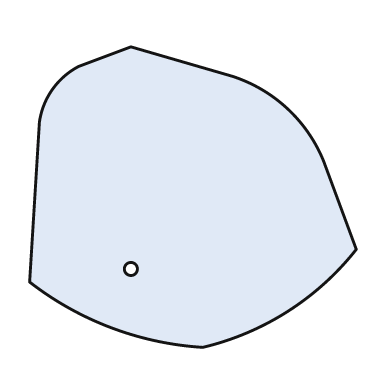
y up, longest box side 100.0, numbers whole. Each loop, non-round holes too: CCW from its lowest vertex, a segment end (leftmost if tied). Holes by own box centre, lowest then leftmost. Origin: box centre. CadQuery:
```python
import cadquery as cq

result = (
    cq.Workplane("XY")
    .moveTo(3.0, -46.0)
    .threePointArc((29.0, -35.0), (50.0, -16.0))
    .lineTo(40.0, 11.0)
    .threePointArc((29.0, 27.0), (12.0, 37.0))
    .lineTo(-19.0, 46.0)
    .lineTo(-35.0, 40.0)
    .threePointArc((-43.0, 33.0), (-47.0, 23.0))
    .lineTo(-50.0, -26.0)
    .threePointArc((-25.0, -40.0), (3.0, -46.0))
    .close()
    .moveTo(-19.0, -22.0)
    .circle(2.0)
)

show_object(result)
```